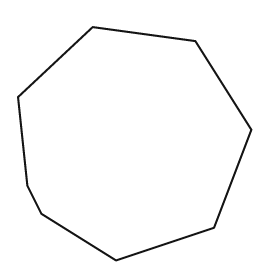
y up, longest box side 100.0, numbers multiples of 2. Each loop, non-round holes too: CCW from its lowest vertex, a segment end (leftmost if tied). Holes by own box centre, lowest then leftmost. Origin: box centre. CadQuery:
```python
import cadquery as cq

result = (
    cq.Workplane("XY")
    .moveTo(-8.0, -50.0)
    .lineTo(34.0, -36.0)
    .lineTo(50.0, 6.0)
    .lineTo(26.0, 44.0)
    .lineTo(-18.0, 50.0)
    .lineTo(-50.0, 20.0)
    .lineTo(-46.0, -18.0)
    .lineTo(-40.0, -30.0)
    .close()
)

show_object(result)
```